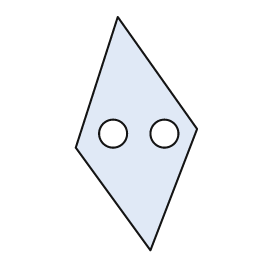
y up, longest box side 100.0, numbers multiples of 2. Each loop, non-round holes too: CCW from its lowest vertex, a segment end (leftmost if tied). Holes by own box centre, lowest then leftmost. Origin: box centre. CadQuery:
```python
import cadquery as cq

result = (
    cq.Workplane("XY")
    .moveTo(6.0, -50.0)
    .lineTo(26.0, 2.0)
    .lineTo(-8.0, 50.0)
    .lineTo(-26.0, -6.0)
    .close()
    .moveTo(-10.0, 0.0)
    .circle(6.0)
    .moveTo(12.0, 0.0)
    .circle(6.0)
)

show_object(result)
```